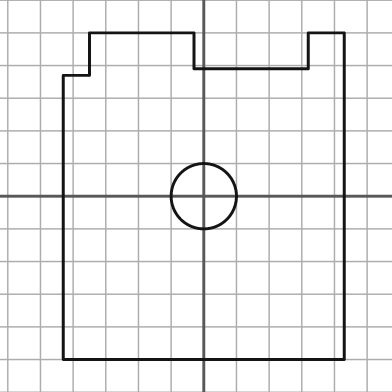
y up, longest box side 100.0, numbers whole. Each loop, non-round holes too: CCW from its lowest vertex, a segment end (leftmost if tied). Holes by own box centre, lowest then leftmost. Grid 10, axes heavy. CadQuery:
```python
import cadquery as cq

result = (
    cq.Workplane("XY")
    .moveTo(-43.0, -50.0)
    .lineTo(43.0, -50.0)
    .lineTo(43.0, 50.0)
    .lineTo(32.0, 50.0)
    .lineTo(32.0, 39.0)
    .lineTo(-3.0, 39.0)
    .lineTo(-3.0, 50.0)
    .lineTo(-35.0, 50.0)
    .lineTo(-35.0, 37.0)
    .lineTo(-43.0, 37.0)
    .close()
    .moveTo(0.0, 0.0)
    .circle(10.0)
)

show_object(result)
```